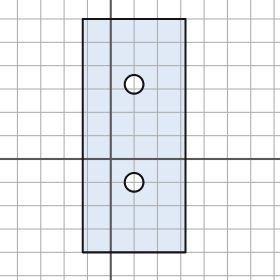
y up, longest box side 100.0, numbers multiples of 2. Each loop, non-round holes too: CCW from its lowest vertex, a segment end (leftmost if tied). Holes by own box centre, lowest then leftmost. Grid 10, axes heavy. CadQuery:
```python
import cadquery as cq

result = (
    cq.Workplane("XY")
    .moveTo(-12.0, -40.0)
    .lineTo(32.0, -40.0)
    .lineTo(32.0, 60.0)
    .lineTo(-12.0, 60.0)
    .close()
    .moveTo(10.0, -10.0)
    .circle(4.0)
    .moveTo(10.0, 32.0)
    .circle(4.0)
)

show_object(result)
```